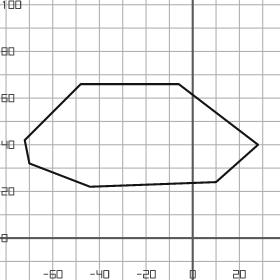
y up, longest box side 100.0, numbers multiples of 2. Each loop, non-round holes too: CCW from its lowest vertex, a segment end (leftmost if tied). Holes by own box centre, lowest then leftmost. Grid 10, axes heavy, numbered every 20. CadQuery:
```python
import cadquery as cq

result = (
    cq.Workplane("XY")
    .moveTo(-44.0, 22.0)
    .lineTo(10.0, 24.0)
    .lineTo(28.0, 40.0)
    .lineTo(-6.0, 66.0)
    .lineTo(-48.0, 66.0)
    .lineTo(-72.0, 42.0)
    .lineTo(-70.0, 32.0)
    .close()
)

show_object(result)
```